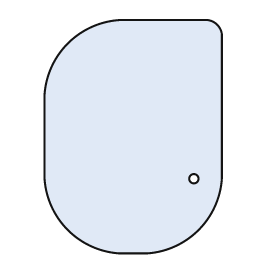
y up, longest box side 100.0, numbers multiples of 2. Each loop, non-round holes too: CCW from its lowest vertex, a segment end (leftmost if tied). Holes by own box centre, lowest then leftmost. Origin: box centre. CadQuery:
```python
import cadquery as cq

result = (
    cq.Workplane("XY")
    .moveTo(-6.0, -50.0)
    .lineTo(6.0, -50.0)
    .threePointArc((28.0, -40.0), (38.0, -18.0))
    .lineTo(38.0, 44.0)
    .threePointArc((36.0, 48.0), (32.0, 50.0))
    .lineTo(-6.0, 50.0)
    .threePointArc((-28.0, 40.0), (-38.0, 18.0))
    .lineTo(-38.0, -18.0)
    .threePointArc((-28.0, -40.0), (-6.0, -50.0))
    .close()
    .moveTo(26.0, -18.0)
    .circle(2.0)
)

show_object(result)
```